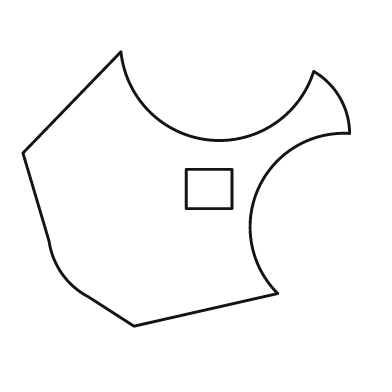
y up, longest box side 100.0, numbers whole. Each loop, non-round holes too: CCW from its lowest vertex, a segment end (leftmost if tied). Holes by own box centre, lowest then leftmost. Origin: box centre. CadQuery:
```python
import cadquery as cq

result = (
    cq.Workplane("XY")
    .moveTo(-16.0, -42.0)
    .lineTo(28.0, -32.0)
    .threePointArc((22.0, 0.0), (50.0, 17.0))
    .threePointArc((47.0, 28.0), (39.0, 36.0))
    .threePointArc((7.0, 15.0), (-20.0, 42.0))
    .lineTo(-50.0, 11.0)
    .lineTo(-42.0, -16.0)
    .threePointArc((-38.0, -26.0), (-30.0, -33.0))
    .close()
    .moveTo(0.0, -6.0)
    .lineTo(14.0, -6.0)
    .lineTo(14.0, 6.0)
    .lineTo(0.0, 6.0)
    .close()
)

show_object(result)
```